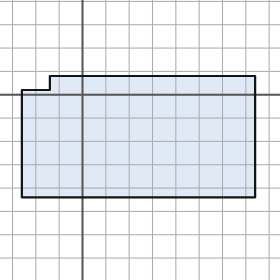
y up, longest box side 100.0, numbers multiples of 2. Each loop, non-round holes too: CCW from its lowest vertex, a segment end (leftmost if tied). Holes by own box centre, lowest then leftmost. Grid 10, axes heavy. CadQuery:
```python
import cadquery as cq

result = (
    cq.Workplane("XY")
    .moveTo(-26.0, -44.0)
    .lineTo(74.0, -44.0)
    .lineTo(74.0, 8.0)
    .lineTo(-14.0, 8.0)
    .lineTo(-14.0, 2.0)
    .lineTo(-26.0, 2.0)
    .close()
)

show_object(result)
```